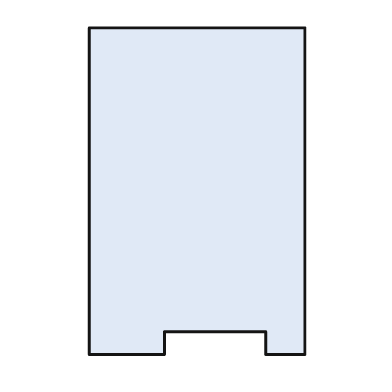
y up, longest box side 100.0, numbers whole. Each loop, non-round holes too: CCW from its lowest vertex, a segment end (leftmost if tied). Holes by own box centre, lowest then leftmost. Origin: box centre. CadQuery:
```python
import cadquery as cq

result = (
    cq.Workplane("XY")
    .moveTo(-33.0, -50.0)
    .lineTo(-10.0, -50.0)
    .lineTo(-10.0, -43.0)
    .lineTo(21.0, -43.0)
    .lineTo(21.0, -50.0)
    .lineTo(33.0, -50.0)
    .lineTo(33.0, 50.0)
    .lineTo(-33.0, 50.0)
    .close()
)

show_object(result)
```